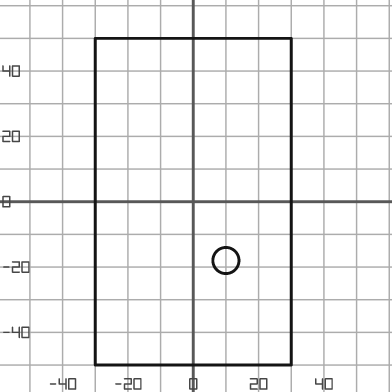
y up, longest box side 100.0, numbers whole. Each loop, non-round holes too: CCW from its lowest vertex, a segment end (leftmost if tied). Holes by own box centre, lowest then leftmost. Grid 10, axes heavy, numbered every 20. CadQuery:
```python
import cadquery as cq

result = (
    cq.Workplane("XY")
    .moveTo(-30.0, -50.0)
    .lineTo(30.0, -50.0)
    .lineTo(30.0, 50.0)
    .lineTo(-30.0, 50.0)
    .close()
    .moveTo(10.0, -18.0)
    .circle(4.0)
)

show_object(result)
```